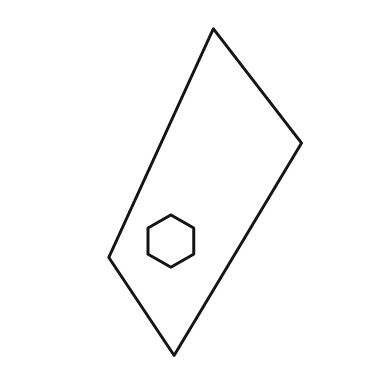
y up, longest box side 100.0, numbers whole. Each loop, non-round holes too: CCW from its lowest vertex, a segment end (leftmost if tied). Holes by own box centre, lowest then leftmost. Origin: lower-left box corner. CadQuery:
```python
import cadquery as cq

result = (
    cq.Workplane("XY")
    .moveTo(20.0, 0.0)
    .lineTo(59.0, 65.0)
    .lineTo(32.0, 100.0)
    .lineTo(0.0, 30.0)
    .close()
    .moveTo(19.0, 27.0)
    .lineTo(26.0, 31.0)
    .lineTo(26.0, 39.0)
    .lineTo(19.0, 43.0)
    .lineTo(12.0, 39.0)
    .lineTo(12.0, 31.0)
    .close()
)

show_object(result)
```